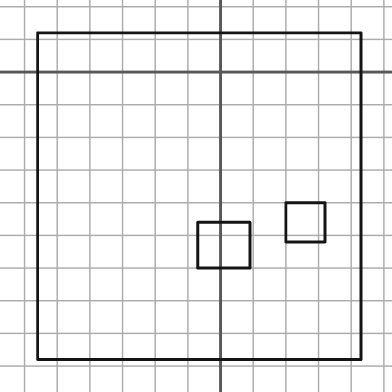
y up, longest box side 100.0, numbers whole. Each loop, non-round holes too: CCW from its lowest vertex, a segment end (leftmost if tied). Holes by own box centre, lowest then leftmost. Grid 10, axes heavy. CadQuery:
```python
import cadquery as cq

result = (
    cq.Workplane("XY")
    .moveTo(-56.0, -88.0)
    .lineTo(43.0, -88.0)
    .lineTo(43.0, 12.0)
    .lineTo(-56.0, 12.0)
    .close()
    .moveTo(-7.0, -60.0)
    .lineTo(9.0, -60.0)
    .lineTo(9.0, -46.0)
    .lineTo(-7.0, -46.0)
    .close()
    .moveTo(20.0, -52.0)
    .lineTo(32.0, -52.0)
    .lineTo(32.0, -40.0)
    .lineTo(20.0, -40.0)
    .close()
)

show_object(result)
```